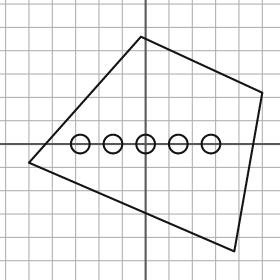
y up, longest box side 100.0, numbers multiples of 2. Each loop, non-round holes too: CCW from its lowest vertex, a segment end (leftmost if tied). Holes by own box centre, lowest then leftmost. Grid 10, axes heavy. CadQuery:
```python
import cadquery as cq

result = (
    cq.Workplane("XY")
    .moveTo(38.0, -46.0)
    .lineTo(50.0, 22.0)
    .lineTo(-2.0, 46.0)
    .lineTo(-50.0, -8.0)
    .close()
    .moveTo(-28.0, 0.0)
    .circle(4.0)
    .moveTo(-14.0, 0.0)
    .circle(4.0)
    .moveTo(0.0, 0.0)
    .circle(4.0)
    .moveTo(14.0, 0.0)
    .circle(4.0)
    .moveTo(28.0, 0.0)
    .circle(4.0)
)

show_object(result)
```